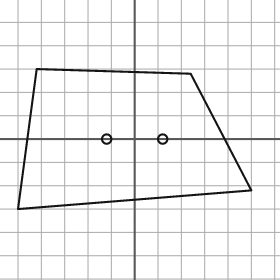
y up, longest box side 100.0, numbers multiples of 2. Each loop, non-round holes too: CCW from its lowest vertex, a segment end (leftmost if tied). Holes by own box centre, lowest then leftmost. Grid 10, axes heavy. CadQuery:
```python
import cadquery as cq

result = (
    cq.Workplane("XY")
    .moveTo(-50.0, -30.0)
    .lineTo(50.0, -22.0)
    .lineTo(24.0, 28.0)
    .lineTo(-42.0, 30.0)
    .close()
    .moveTo(-12.0, 0.0)
    .circle(2.0)
    .moveTo(12.0, 0.0)
    .circle(2.0)
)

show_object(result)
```